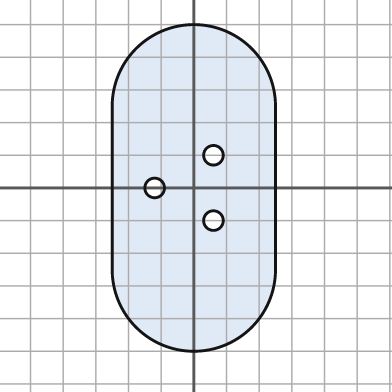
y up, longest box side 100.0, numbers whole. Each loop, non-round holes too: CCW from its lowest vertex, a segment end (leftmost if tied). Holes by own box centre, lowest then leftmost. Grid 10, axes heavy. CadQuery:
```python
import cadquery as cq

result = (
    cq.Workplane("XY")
    .moveTo(-25.0, -25.0)
    .threePointArc((0.0, -50.0), (25.0, -25.0))
    .lineTo(25.0, 25.0)
    .threePointArc((0.0, 50.0), (-25.0, 25.0))
    .close()
    .moveTo(6.0, -10.0)
    .circle(3.0)
    .moveTo(-12.0, 0.0)
    .circle(3.0)
    .moveTo(6.0, 10.0)
    .circle(3.0)
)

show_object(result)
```